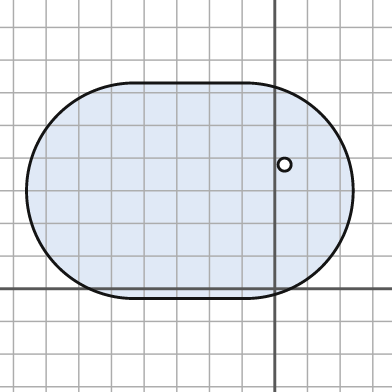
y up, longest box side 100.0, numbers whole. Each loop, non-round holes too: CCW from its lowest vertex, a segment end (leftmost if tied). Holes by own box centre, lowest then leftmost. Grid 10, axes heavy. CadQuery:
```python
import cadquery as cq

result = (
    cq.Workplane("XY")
    .moveTo(-43.0, -3.0)
    .lineTo(-9.0, -3.0)
    .threePointArc((24.0, 30.0), (-9.0, 63.0))
    .lineTo(-43.0, 63.0)
    .threePointArc((-76.0, 30.0), (-43.0, -3.0))
    .close()
    .moveTo(3.0, 38.0)
    .circle(2.0)
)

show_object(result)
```